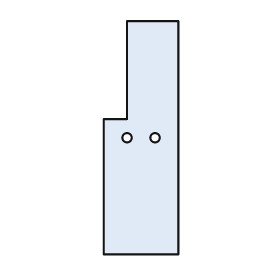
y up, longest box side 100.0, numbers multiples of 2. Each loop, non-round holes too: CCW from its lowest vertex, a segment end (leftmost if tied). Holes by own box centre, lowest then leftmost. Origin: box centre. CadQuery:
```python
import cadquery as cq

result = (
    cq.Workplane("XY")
    .moveTo(-16.0, -50.0)
    .lineTo(16.0, -50.0)
    .lineTo(16.0, 50.0)
    .lineTo(-6.0, 50.0)
    .lineTo(-6.0, 8.0)
    .lineTo(-16.0, 8.0)
    .close()
    .moveTo(-6.0, 0.0)
    .circle(2.0)
    .moveTo(6.0, 0.0)
    .circle(2.0)
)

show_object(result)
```